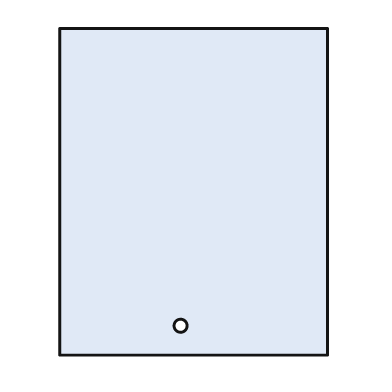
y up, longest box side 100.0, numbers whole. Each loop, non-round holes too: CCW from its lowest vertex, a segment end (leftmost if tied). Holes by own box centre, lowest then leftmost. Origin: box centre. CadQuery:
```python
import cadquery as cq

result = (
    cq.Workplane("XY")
    .moveTo(-41.0, -50.0)
    .lineTo(41.0, -50.0)
    .lineTo(41.0, 50.0)
    .lineTo(-41.0, 50.0)
    .close()
    .moveTo(-4.0, -41.0)
    .circle(2.0)
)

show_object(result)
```